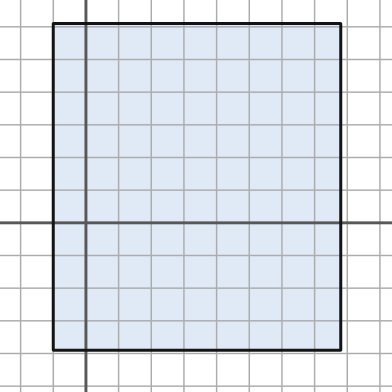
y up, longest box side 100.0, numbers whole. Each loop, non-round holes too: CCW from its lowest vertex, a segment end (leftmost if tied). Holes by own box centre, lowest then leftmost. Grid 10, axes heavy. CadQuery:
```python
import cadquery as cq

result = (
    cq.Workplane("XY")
    .moveTo(-10.0, -39.0)
    .lineTo(78.0, -39.0)
    .lineTo(78.0, 61.0)
    .lineTo(-10.0, 61.0)
    .close()
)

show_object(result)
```